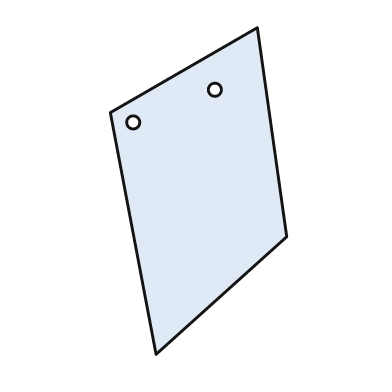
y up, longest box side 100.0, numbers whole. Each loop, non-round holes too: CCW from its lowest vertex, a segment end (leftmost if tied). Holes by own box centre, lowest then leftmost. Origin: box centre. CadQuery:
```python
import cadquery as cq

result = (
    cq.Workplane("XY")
    .moveTo(-13.0, -50.0)
    .lineTo(27.0, -14.0)
    .lineTo(18.0, 50.0)
    .lineTo(-27.0, 24.0)
    .close()
    .moveTo(-20.0, 21.0)
    .circle(2.0)
    .moveTo(5.0, 31.0)
    .circle(2.0)
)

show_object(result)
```